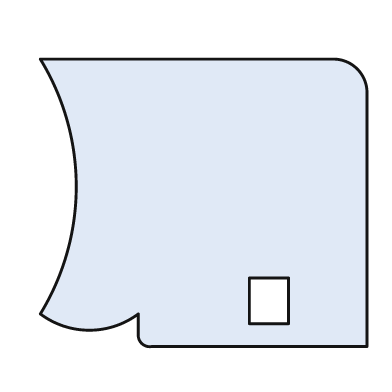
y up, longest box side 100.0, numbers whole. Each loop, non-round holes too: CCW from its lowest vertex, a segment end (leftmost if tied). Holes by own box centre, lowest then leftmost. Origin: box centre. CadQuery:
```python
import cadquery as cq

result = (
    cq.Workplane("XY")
    .moveTo(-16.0, -44.0)
    .lineTo(50.0, -44.0)
    .lineTo(50.0, 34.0)
    .threePointArc((47.0, 41.0), (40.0, 44.0))
    .lineTo(-50.0, 44.0)
    .threePointArc((-39.0, 5.0), (-50.0, -34.0))
    .threePointArc((-35.0, -39.0), (-20.0, -34.0))
    .lineTo(-20.0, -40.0)
    .threePointArc((-19.0, -43.0), (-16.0, -44.0))
    .close()
    .moveTo(14.0, -37.0)
    .lineTo(26.0, -37.0)
    .lineTo(26.0, -23.0)
    .lineTo(14.0, -23.0)
    .close()
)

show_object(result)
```